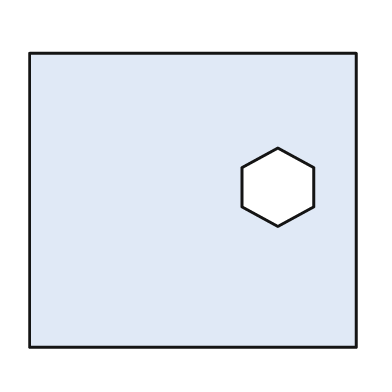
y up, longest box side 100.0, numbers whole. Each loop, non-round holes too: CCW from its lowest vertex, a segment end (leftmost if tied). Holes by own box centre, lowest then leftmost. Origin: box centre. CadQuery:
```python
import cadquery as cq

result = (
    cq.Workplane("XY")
    .moveTo(-50.0, -45.0)
    .lineTo(50.0, -45.0)
    .lineTo(50.0, 45.0)
    .lineTo(-50.0, 45.0)
    .close()
    .moveTo(26.0, -8.0)
    .lineTo(37.0, -2.0)
    .lineTo(37.0, 10.0)
    .lineTo(26.0, 16.0)
    .lineTo(15.0, 10.0)
    .lineTo(15.0, -2.0)
    .close()
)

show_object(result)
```